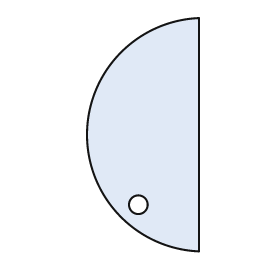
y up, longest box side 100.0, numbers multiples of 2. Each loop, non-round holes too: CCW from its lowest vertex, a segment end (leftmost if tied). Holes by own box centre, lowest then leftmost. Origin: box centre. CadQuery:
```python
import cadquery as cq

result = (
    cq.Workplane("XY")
    .moveTo(24.0, -50.0)
    .lineTo(24.0, 50.0)
    .threePointArc((-24.0, 0.0), (24.0, -50.0))
    .close()
    .moveTo(-2.0, -30.0)
    .circle(4.0)
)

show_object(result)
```